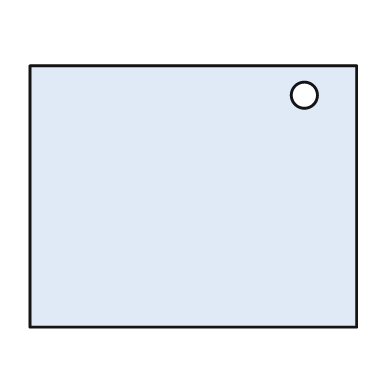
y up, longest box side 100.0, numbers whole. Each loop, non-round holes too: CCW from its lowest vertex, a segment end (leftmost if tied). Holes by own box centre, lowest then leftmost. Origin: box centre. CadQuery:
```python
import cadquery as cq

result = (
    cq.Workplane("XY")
    .moveTo(-50.0, -40.0)
    .lineTo(50.0, -40.0)
    .lineTo(50.0, 40.0)
    .lineTo(-50.0, 40.0)
    .close()
    .moveTo(34.0, 31.0)
    .circle(4.0)
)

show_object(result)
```